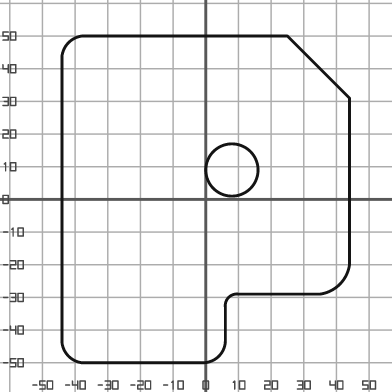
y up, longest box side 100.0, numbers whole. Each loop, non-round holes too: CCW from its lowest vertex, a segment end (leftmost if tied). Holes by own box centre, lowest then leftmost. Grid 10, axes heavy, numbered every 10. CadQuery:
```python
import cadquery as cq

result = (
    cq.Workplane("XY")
    .moveTo(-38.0, -50.0)
    .lineTo(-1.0, -50.0)
    .threePointArc((4.0, -48.0), (6.0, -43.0))
    .lineTo(6.0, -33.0)
    .threePointArc((7.0, -30.0), (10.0, -29.0))
    .lineTo(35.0, -29.0)
    .threePointArc((41.0, -26.0), (44.0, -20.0))
    .lineTo(44.0, 31.0)
    .lineTo(25.0, 50.0)
    .lineTo(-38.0, 50.0)
    .threePointArc((-42.0, 48.0), (-44.0, 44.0))
    .lineTo(-44.0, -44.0)
    .threePointArc((-42.0, -48.0), (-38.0, -50.0))
    .close()
    .moveTo(8.0, 9.0)
    .circle(8.0)
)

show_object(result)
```